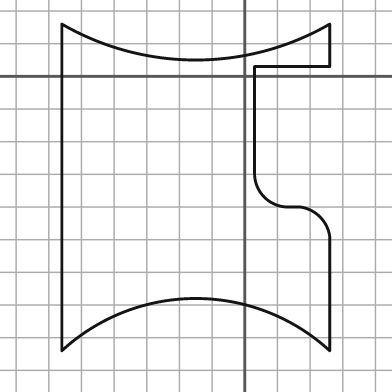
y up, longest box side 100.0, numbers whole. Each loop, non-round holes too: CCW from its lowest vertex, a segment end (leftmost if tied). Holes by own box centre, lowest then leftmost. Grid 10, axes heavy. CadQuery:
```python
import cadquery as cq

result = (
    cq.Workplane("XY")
    .moveTo(-56.0, -84.0)
    .threePointArc((-15.0, -68.0), (26.0, -84.0))
    .lineTo(26.0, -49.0)
    .threePointArc((23.0, -43.0), (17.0, -40.0))
    .lineTo(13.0, -40.0)
    .threePointArc((6.0, -37.0), (3.0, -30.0))
    .lineTo(3.0, 3.0)
    .lineTo(26.0, 3.0)
    .lineTo(26.0, 16.0)
    .threePointArc((-15.0, 5.0), (-56.0, 16.0))
    .close()
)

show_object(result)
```